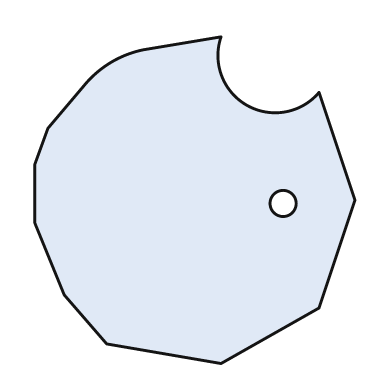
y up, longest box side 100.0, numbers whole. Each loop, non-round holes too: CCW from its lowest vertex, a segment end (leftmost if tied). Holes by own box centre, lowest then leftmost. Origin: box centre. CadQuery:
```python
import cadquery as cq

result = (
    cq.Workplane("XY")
    .moveTo(8.0, -50.0)
    .lineTo(38.0, -33.0)
    .lineTo(49.0, 0.0)
    .lineTo(38.0, 33.0)
    .threePointArc((16.0, 29.0), (8.0, 50.0))
    .lineTo(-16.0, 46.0)
    .threePointArc((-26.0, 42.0), (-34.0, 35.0))
    .lineTo(-45.0, 22.0)
    .lineTo(-49.0, 11.0)
    .lineTo(-49.0, -7.0)
    .lineTo(-40.0, -29.0)
    .lineTo(-27.0, -44.0)
    .close()
    .moveTo(27.0, -1.0)
    .circle(4.0)
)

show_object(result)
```